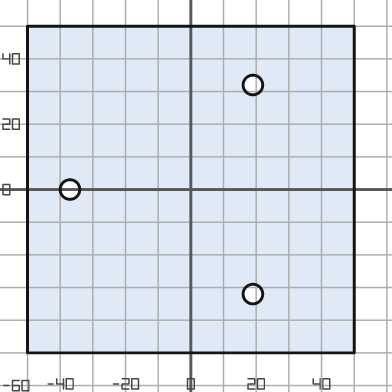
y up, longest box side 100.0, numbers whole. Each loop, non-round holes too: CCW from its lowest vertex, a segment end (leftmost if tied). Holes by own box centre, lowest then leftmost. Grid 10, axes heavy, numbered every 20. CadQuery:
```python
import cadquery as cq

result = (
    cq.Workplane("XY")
    .moveTo(-50.0, -50.0)
    .lineTo(50.0, -50.0)
    .lineTo(50.0, 50.0)
    .lineTo(-50.0, 50.0)
    .close()
    .moveTo(19.0, -32.0)
    .circle(3.0)
    .moveTo(-37.0, 0.0)
    .circle(3.0)
    .moveTo(19.0, 32.0)
    .circle(3.0)
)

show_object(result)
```